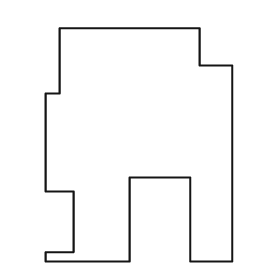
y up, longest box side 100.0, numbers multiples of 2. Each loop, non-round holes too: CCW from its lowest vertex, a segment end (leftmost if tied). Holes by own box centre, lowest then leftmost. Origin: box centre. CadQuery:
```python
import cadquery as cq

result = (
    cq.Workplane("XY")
    .moveTo(-40.0, -50.0)
    .lineTo(-4.0, -50.0)
    .lineTo(-4.0, -14.0)
    .lineTo(22.0, -14.0)
    .lineTo(22.0, -50.0)
    .lineTo(40.0, -50.0)
    .lineTo(40.0, 34.0)
    .lineTo(26.0, 34.0)
    .lineTo(26.0, 50.0)
    .lineTo(-34.0, 50.0)
    .lineTo(-34.0, 22.0)
    .lineTo(-40.0, 22.0)
    .lineTo(-40.0, -20.0)
    .lineTo(-28.0, -20.0)
    .lineTo(-28.0, -46.0)
    .lineTo(-40.0, -46.0)
    .close()
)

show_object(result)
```